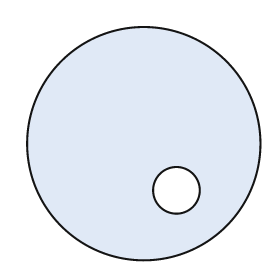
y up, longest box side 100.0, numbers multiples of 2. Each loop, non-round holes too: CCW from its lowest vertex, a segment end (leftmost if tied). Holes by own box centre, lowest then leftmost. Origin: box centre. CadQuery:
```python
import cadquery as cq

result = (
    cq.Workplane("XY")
    .moveTo(0.0, 0.0)
    .circle(50.0)
    .moveTo(14.0, -20.0)
    .circle(10.0)
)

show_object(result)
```